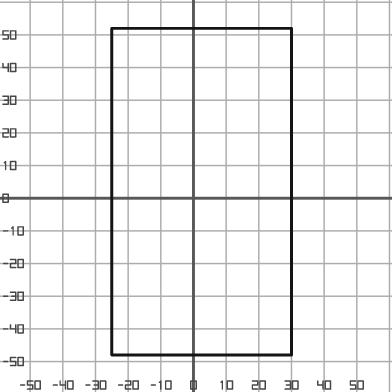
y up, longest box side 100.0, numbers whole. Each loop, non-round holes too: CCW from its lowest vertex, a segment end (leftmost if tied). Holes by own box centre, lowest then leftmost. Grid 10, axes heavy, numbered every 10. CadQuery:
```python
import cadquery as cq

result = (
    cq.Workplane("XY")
    .moveTo(-25.0, -48.0)
    .lineTo(30.0, -48.0)
    .lineTo(30.0, 52.0)
    .lineTo(-25.0, 52.0)
    .close()
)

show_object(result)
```